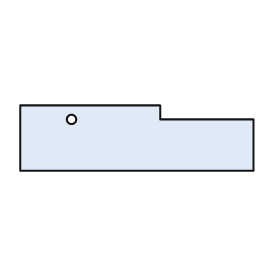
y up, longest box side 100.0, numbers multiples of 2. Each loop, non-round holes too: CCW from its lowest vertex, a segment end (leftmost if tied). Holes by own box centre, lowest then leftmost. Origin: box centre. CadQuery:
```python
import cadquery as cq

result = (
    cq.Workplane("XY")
    .moveTo(-50.0, -14.0)
    .lineTo(50.0, -14.0)
    .lineTo(50.0, 8.0)
    .lineTo(10.0, 8.0)
    .lineTo(10.0, 14.0)
    .lineTo(-50.0, 14.0)
    .close()
    .moveTo(-28.0, 8.0)
    .circle(2.0)
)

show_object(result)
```